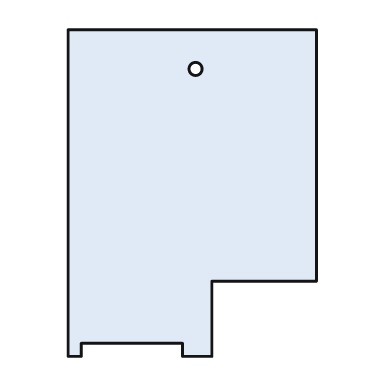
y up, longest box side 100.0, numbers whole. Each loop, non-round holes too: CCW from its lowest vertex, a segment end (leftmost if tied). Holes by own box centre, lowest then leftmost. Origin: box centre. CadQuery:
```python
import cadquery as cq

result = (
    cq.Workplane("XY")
    .moveTo(-38.0, -50.0)
    .lineTo(-34.0, -50.0)
    .lineTo(-34.0, -46.0)
    .lineTo(-3.0, -46.0)
    .lineTo(-3.0, -50.0)
    .lineTo(6.0, -50.0)
    .lineTo(6.0, -27.0)
    .lineTo(38.0, -27.0)
    .lineTo(38.0, 50.0)
    .lineTo(-38.0, 50.0)
    .close()
    .moveTo(1.0, 38.0)
    .circle(2.0)
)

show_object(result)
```